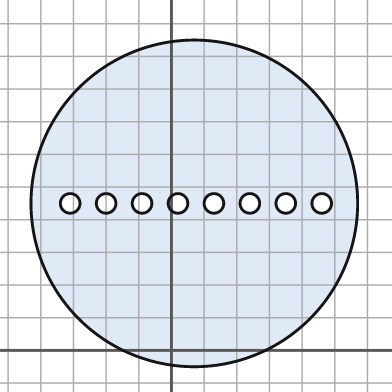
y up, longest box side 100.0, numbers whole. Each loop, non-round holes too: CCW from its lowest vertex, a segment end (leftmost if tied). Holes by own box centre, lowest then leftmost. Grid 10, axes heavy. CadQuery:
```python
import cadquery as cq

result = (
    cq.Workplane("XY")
    .moveTo(7.0, 45.0)
    .circle(50.0)
    .moveTo(-31.0, 45.0)
    .circle(3.0)
    .moveTo(-20.0, 45.0)
    .circle(3.0)
    .moveTo(-9.0, 45.0)
    .circle(3.0)
    .moveTo(2.0, 45.0)
    .circle(3.0)
    .moveTo(13.0, 45.0)
    .circle(3.0)
    .moveTo(24.0, 45.0)
    .circle(3.0)
    .moveTo(35.0, 45.0)
    .circle(3.0)
    .moveTo(46.0, 45.0)
    .circle(3.0)
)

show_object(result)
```